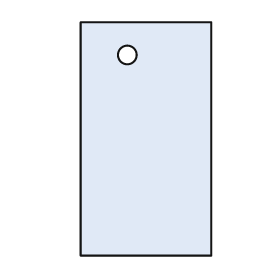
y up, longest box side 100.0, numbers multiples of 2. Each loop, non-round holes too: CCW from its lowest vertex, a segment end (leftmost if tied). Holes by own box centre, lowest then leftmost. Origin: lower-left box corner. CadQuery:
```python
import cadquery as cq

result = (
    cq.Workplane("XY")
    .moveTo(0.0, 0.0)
    .lineTo(56.0, 0.0)
    .lineTo(56.0, 100.0)
    .lineTo(0.0, 100.0)
    .close()
    .moveTo(20.0, 86.0)
    .circle(4.0)
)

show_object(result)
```